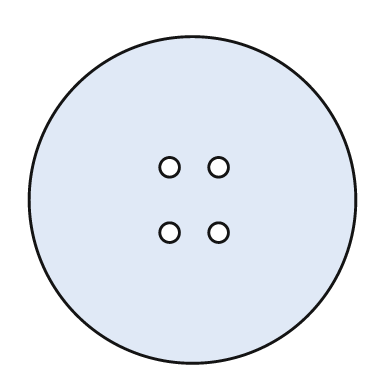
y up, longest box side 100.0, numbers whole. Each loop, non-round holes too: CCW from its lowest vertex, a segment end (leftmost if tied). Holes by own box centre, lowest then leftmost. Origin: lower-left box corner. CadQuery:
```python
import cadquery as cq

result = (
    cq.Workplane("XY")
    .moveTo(50.0, 50.0)
    .circle(50.0)
    .moveTo(43.0, 40.0)
    .circle(3.0)
    .moveTo(58.0, 40.0)
    .circle(3.0)
    .moveTo(43.0, 60.0)
    .circle(3.0)
    .moveTo(58.0, 60.0)
    .circle(3.0)
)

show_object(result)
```